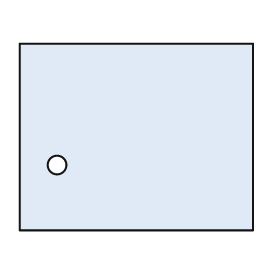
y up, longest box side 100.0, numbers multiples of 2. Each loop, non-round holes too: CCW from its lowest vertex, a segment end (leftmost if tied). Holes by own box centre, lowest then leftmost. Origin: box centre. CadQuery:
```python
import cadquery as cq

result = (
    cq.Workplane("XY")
    .moveTo(-50.0, -40.0)
    .lineTo(50.0, -40.0)
    .lineTo(50.0, 40.0)
    .lineTo(-50.0, 40.0)
    .close()
    .moveTo(-34.0, -12.0)
    .circle(4.0)
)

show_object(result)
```